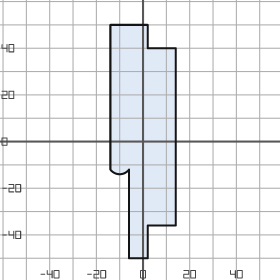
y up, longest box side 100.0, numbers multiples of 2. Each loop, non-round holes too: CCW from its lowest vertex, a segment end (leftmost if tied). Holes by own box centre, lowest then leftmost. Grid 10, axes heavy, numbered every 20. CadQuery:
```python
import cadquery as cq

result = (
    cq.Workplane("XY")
    .moveTo(-6.0, -50.0)
    .lineTo(2.0, -50.0)
    .lineTo(2.0, -36.0)
    .lineTo(14.0, -36.0)
    .lineTo(14.0, 40.0)
    .lineTo(2.0, 40.0)
    .lineTo(2.0, 50.0)
    .lineTo(-14.0, 50.0)
    .lineTo(-14.0, -12.0)
    .threePointArc((-10.0, -14.0), (-6.0, -12.0))
    .close()
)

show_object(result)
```